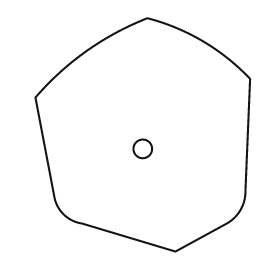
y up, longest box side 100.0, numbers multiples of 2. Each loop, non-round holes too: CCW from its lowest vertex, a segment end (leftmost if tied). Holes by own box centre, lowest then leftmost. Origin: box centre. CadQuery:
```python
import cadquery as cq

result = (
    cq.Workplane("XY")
    .moveTo(14.0, -50.0)
    .lineTo(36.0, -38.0)
    .threePointArc((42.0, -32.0), (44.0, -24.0))
    .lineTo(46.0, 24.0)
    .threePointArc((26.0, 40.0), (2.0, 50.0))
    .threePointArc((-24.0, 36.0), (-46.0, 16.0))
    .lineTo(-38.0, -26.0)
    .threePointArc((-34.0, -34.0), (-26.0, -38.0))
    .close()
    .moveTo(0.0, -6.0)
    .circle(4.0)
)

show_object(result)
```